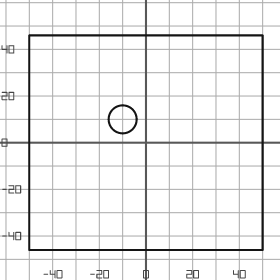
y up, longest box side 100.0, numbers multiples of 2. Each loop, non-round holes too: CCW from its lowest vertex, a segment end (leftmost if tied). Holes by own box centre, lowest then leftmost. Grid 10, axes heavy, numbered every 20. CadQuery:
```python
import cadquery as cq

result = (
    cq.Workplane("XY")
    .moveTo(-50.0, -46.0)
    .lineTo(50.0, -46.0)
    .lineTo(50.0, 46.0)
    .lineTo(-50.0, 46.0)
    .close()
    .moveTo(-10.0, 10.0)
    .circle(6.0)
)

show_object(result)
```